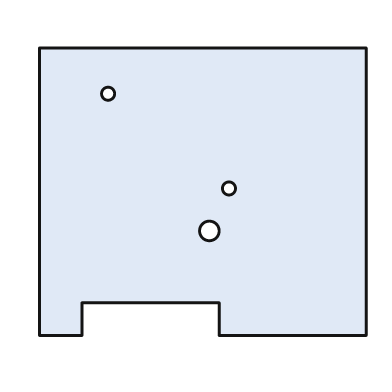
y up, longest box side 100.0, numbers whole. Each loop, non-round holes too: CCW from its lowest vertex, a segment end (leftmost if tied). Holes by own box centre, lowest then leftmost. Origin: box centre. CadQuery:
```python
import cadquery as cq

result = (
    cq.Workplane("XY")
    .moveTo(-50.0, -44.0)
    .lineTo(-37.0, -44.0)
    .lineTo(-37.0, -34.0)
    .lineTo(5.0, -34.0)
    .lineTo(5.0, -44.0)
    .lineTo(50.0, -44.0)
    .lineTo(50.0, 44.0)
    .lineTo(-50.0, 44.0)
    .close()
    .moveTo(2.0, -12.0)
    .circle(3.0)
    .moveTo(8.0, 1.0)
    .circle(2.0)
    .moveTo(-29.0, 30.0)
    .circle(2.0)
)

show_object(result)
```